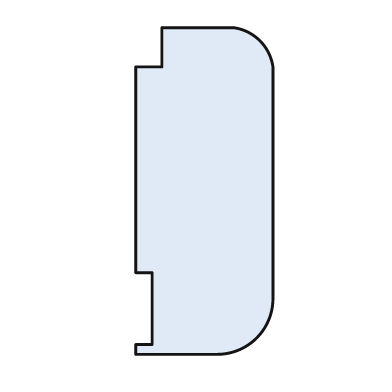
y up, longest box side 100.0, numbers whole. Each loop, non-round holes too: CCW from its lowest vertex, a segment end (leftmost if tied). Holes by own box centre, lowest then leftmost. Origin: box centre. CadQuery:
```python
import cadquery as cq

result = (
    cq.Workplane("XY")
    .moveTo(-21.0, -50.0)
    .lineTo(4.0, -50.0)
    .threePointArc((16.0, -45.0), (21.0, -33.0))
    .lineTo(21.0, 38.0)
    .threePointArc((17.0, 46.0), (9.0, 50.0))
    .lineTo(-13.0, 50.0)
    .lineTo(-13.0, 38.0)
    .lineTo(-21.0, 38.0)
    .lineTo(-21.0, -25.0)
    .lineTo(-16.0, -25.0)
    .lineTo(-16.0, -47.0)
    .lineTo(-21.0, -47.0)
    .close()
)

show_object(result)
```